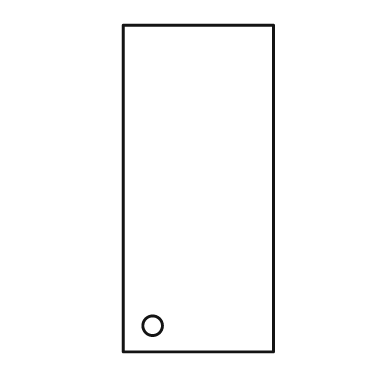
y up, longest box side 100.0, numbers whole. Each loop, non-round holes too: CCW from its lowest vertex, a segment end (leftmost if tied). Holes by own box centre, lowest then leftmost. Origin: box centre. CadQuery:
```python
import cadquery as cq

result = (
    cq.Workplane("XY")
    .moveTo(-23.0, -50.0)
    .lineTo(23.0, -50.0)
    .lineTo(23.0, 50.0)
    .lineTo(-23.0, 50.0)
    .close()
    .moveTo(-14.0, -42.0)
    .circle(3.0)
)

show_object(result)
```